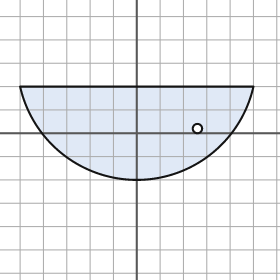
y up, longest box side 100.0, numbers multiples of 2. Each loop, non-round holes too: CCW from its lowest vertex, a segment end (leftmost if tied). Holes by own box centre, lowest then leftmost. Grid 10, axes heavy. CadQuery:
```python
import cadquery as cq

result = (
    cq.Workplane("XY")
    .moveTo(-50.0, 20.0)
    .threePointArc((0.0, -20.0), (50.0, 20.0))
    .close()
    .moveTo(26.0, 2.0)
    .circle(2.0)
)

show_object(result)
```